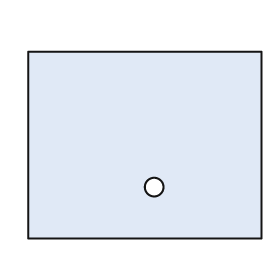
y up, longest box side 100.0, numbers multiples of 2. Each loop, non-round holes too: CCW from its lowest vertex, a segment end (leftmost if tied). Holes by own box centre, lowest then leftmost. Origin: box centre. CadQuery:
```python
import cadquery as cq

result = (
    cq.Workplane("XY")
    .moveTo(-50.0, -40.0)
    .lineTo(50.0, -40.0)
    .lineTo(50.0, 40.0)
    .lineTo(-50.0, 40.0)
    .close()
    .moveTo(4.0, -18.0)
    .circle(4.0)
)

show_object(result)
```